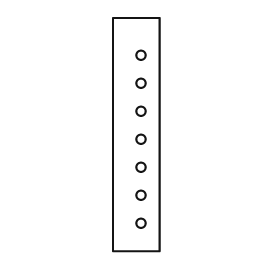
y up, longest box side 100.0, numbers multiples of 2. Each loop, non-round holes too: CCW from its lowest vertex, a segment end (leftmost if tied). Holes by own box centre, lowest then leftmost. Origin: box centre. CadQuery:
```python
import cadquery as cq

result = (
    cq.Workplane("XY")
    .moveTo(-10.0, -50.0)
    .lineTo(10.0, -50.0)
    .lineTo(10.0, 50.0)
    .lineTo(-10.0, 50.0)
    .close()
    .moveTo(2.0, -38.0)
    .circle(2.0)
    .moveTo(2.0, -26.0)
    .circle(2.0)
    .moveTo(2.0, -14.0)
    .circle(2.0)
    .moveTo(2.0, -2.0)
    .circle(2.0)
    .moveTo(2.0, 10.0)
    .circle(2.0)
    .moveTo(2.0, 22.0)
    .circle(2.0)
    .moveTo(2.0, 34.0)
    .circle(2.0)
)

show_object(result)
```